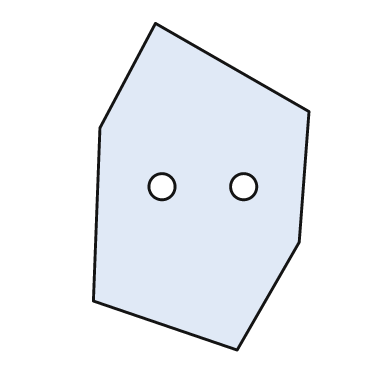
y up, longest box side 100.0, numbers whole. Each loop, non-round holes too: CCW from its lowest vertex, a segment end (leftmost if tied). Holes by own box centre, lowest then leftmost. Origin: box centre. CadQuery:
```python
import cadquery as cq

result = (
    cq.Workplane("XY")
    .moveTo(11.0, -50.0)
    .lineTo(30.0, -17.0)
    .lineTo(33.0, 23.0)
    .lineTo(-14.0, 50.0)
    .lineTo(-31.0, 18.0)
    .lineTo(-33.0, -35.0)
    .close()
    .moveTo(-12.0, 0.0)
    .circle(4.0)
    .moveTo(13.0, 0.0)
    .circle(4.0)
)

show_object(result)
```